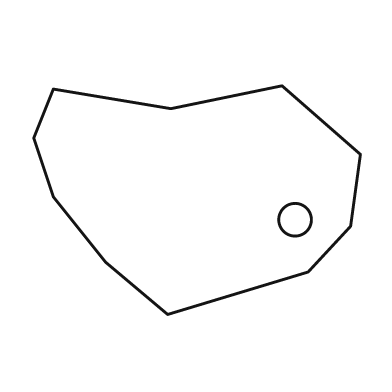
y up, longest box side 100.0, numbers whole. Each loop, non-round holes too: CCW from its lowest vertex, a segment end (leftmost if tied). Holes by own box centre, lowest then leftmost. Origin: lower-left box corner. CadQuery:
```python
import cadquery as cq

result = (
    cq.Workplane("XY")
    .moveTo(41.0, 0.0)
    .lineTo(84.0, 13.0)
    .lineTo(97.0, 27.0)
    .lineTo(100.0, 49.0)
    .lineTo(76.0, 70.0)
    .lineTo(42.0, 63.0)
    .lineTo(6.0, 69.0)
    .lineTo(0.0, 54.0)
    .lineTo(6.0, 36.0)
    .lineTo(22.0, 16.0)
    .close()
    .moveTo(80.0, 29.0)
    .circle(5.0)
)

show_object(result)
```